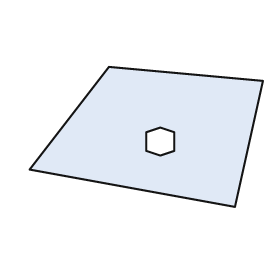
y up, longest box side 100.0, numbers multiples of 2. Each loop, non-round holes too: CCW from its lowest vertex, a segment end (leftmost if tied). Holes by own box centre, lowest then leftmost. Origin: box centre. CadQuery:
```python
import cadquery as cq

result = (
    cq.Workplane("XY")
    .moveTo(38.0, -30.0)
    .lineTo(50.0, 24.0)
    .lineTo(-16.0, 30.0)
    .lineTo(-50.0, -14.0)
    .close()
    .moveTo(6.0, -8.0)
    .lineTo(12.0, -6.0)
    .lineTo(12.0, 2.0)
    .lineTo(6.0, 4.0)
    .lineTo(0.0, 2.0)
    .lineTo(0.0, -6.0)
    .close()
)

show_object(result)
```